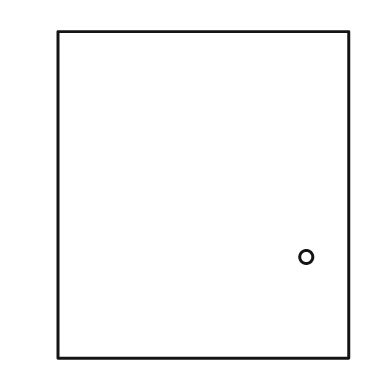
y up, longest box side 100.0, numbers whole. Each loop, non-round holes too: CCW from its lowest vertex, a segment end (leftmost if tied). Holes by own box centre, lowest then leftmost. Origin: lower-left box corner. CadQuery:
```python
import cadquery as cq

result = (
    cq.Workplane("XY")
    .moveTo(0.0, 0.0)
    .lineTo(89.0, 0.0)
    .lineTo(89.0, 100.0)
    .lineTo(0.0, 100.0)
    .close()
    .moveTo(76.0, 31.0)
    .circle(2.0)
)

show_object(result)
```